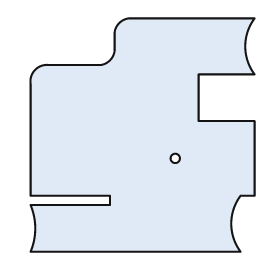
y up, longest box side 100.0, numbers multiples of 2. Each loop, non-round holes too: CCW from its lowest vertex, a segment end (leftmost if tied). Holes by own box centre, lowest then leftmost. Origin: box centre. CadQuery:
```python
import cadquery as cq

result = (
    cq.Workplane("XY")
    .moveTo(-48.0, -50.0)
    .lineTo(42.0, -50.0)
    .threePointArc((38.0, -38.0), (42.0, -26.0))
    .lineTo(48.0, -26.0)
    .lineTo(48.0, 6.0)
    .lineTo(24.0, 6.0)
    .lineTo(24.0, 26.0)
    .lineTo(48.0, 26.0)
    .threePointArc((44.0, 38.0), (48.0, 50.0))
    .lineTo(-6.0, 50.0)
    .threePointArc((-10.0, 48.0), (-12.0, 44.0))
    .lineTo(-12.0, 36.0)
    .threePointArc((-14.0, 32.0), (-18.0, 30.0))
    .lineTo(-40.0, 30.0)
    .threePointArc((-46.0, 28.0), (-48.0, 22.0))
    .lineTo(-48.0, -26.0)
    .lineTo(-14.0, -26.0)
    .lineTo(-14.0, -30.0)
    .lineTo(-48.0, -30.0)
    .threePointArc((-46.0, -40.0), (-48.0, -50.0))
    .close()
    .moveTo(14.0, -10.0)
    .circle(2.0)
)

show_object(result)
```